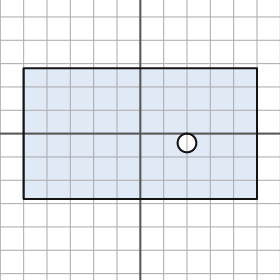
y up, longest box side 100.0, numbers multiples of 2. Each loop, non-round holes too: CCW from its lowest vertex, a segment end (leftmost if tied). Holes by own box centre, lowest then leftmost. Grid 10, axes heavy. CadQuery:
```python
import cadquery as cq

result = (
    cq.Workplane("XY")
    .moveTo(-50.0, -28.0)
    .lineTo(50.0, -28.0)
    .lineTo(50.0, 28.0)
    .lineTo(-50.0, 28.0)
    .close()
    .moveTo(20.0, -4.0)
    .circle(4.0)
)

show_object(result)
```